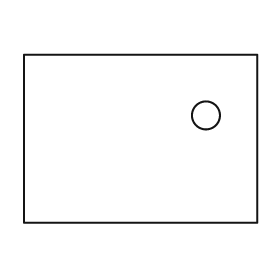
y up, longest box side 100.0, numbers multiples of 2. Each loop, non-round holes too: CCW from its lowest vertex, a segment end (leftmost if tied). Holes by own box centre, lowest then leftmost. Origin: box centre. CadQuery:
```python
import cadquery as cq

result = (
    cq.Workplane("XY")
    .moveTo(-50.0, -36.0)
    .lineTo(50.0, -36.0)
    .lineTo(50.0, 36.0)
    .lineTo(-50.0, 36.0)
    .close()
    .moveTo(28.0, 10.0)
    .circle(6.0)
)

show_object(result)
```